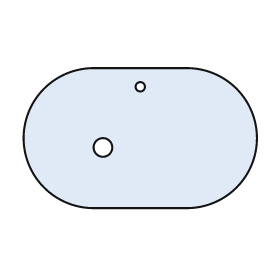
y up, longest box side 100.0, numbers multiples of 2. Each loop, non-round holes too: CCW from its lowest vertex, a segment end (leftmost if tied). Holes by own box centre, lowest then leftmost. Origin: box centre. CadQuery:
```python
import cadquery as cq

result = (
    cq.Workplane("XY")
    .moveTo(-20.0, -30.0)
    .lineTo(20.0, -30.0)
    .threePointArc((50.0, 0.0), (20.0, 30.0))
    .lineTo(-20.0, 30.0)
    .threePointArc((-50.0, 0.0), (-20.0, -30.0))
    .close()
    .moveTo(-16.0, -4.0)
    .circle(4.0)
    .moveTo(0.0, 22.0)
    .circle(2.0)
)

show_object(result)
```